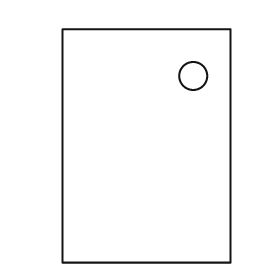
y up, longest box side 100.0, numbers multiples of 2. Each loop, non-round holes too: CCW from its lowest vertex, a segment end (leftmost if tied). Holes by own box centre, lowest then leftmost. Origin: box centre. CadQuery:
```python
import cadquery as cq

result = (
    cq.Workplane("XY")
    .moveTo(-36.0, -50.0)
    .lineTo(36.0, -50.0)
    .lineTo(36.0, 50.0)
    .lineTo(-36.0, 50.0)
    .close()
    .moveTo(20.0, 30.0)
    .circle(6.0)
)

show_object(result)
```